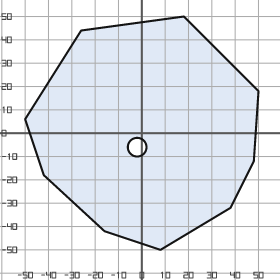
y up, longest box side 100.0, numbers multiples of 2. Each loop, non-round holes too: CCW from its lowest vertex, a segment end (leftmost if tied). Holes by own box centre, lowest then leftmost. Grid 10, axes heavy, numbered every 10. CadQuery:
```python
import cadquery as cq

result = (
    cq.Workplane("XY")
    .moveTo(8.0, -50.0)
    .lineTo(38.0, -32.0)
    .lineTo(48.0, -12.0)
    .lineTo(50.0, 18.0)
    .lineTo(18.0, 50.0)
    .lineTo(-26.0, 44.0)
    .lineTo(-50.0, 6.0)
    .lineTo(-42.0, -18.0)
    .lineTo(-16.0, -42.0)
    .close()
    .moveTo(-2.0, -6.0)
    .circle(4.0)
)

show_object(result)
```